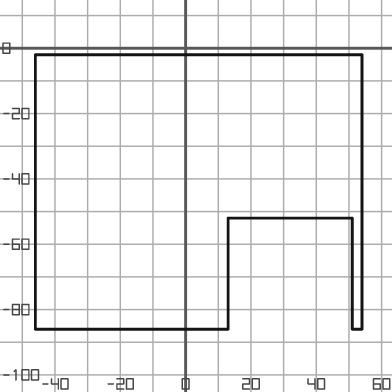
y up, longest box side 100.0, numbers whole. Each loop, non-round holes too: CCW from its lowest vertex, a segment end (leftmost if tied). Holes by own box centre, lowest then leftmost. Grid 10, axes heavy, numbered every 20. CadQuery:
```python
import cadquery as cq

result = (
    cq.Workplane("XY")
    .moveTo(-46.0, -86.0)
    .lineTo(13.0, -86.0)
    .lineTo(13.0, -52.0)
    .lineTo(51.0, -52.0)
    .lineTo(51.0, -86.0)
    .lineTo(54.0, -86.0)
    .lineTo(54.0, -2.0)
    .lineTo(-46.0, -2.0)
    .close()
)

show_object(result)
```